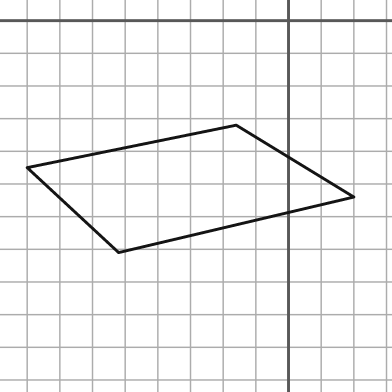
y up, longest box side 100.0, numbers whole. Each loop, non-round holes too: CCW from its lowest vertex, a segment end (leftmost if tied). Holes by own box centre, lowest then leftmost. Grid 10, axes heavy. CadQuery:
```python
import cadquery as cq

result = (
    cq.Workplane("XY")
    .moveTo(-52.0, -71.0)
    .lineTo(20.0, -54.0)
    .lineTo(-16.0, -32.0)
    .lineTo(-80.0, -45.0)
    .close()
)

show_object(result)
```